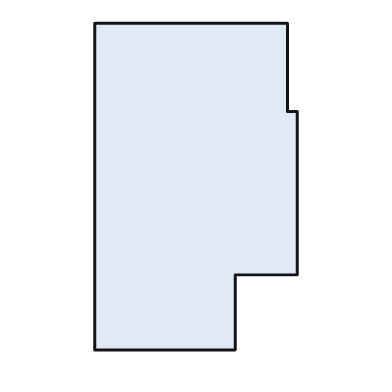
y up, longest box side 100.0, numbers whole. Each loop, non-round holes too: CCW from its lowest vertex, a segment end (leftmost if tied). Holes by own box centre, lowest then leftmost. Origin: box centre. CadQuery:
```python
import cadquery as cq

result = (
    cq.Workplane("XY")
    .moveTo(-31.0, -50.0)
    .lineTo(12.0, -50.0)
    .lineTo(12.0, -27.0)
    .lineTo(31.0, -27.0)
    .lineTo(31.0, 23.0)
    .lineTo(28.0, 23.0)
    .lineTo(28.0, 50.0)
    .lineTo(-31.0, 50.0)
    .close()
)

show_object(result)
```